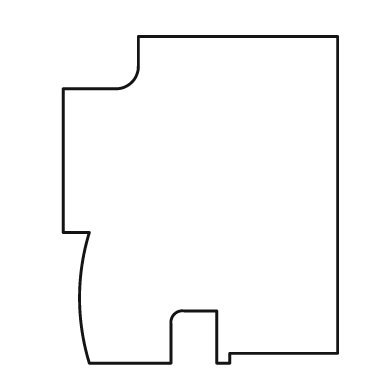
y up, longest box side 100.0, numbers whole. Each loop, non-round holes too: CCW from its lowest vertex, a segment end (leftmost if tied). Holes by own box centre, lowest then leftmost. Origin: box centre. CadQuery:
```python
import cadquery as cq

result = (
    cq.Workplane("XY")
    .moveTo(-34.0, -50.0)
    .lineTo(-9.0, -50.0)
    .lineTo(-9.0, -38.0)
    .threePointArc((-8.0, -35.0), (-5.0, -34.0))
    .lineTo(5.0, -34.0)
    .lineTo(5.0, -50.0)
    .lineTo(9.0, -50.0)
    .lineTo(9.0, -47.0)
    .lineTo(42.0, -47.0)
    .lineTo(42.0, 50.0)
    .lineTo(-19.0, 50.0)
    .lineTo(-19.0, 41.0)
    .threePointArc((-21.0, 36.0), (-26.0, 34.0))
    .lineTo(-42.0, 34.0)
    .lineTo(-42.0, -10.0)
    .lineTo(-34.0, -10.0)
    .threePointArc((-37.0, -30.0), (-34.0, -50.0))
    .close()
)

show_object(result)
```